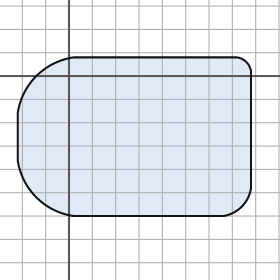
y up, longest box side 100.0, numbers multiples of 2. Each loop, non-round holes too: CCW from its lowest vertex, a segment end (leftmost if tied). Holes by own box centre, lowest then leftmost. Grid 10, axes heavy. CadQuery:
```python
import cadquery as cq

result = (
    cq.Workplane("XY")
    .moveTo(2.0, -60.0)
    .lineTo(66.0, -60.0)
    .threePointArc((74.0, -56.0), (78.0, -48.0))
    .lineTo(78.0, 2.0)
    .threePointArc((76.0, 6.0), (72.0, 8.0))
    .lineTo(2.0, 8.0)
    .threePointArc((-14.0, 0.0), (-22.0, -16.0))
    .lineTo(-22.0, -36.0)
    .threePointArc((-14.0, -52.0), (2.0, -60.0))
    .close()
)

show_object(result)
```